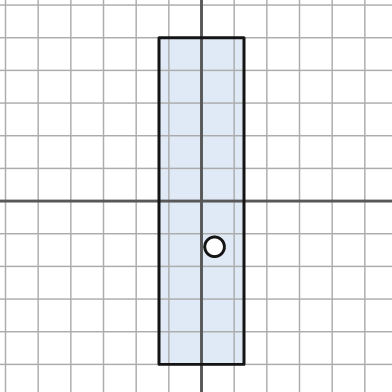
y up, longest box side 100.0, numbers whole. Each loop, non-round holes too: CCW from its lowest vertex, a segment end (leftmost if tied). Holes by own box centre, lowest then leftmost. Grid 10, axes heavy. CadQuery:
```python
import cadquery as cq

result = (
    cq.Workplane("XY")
    .moveTo(-13.0, -50.0)
    .lineTo(13.0, -50.0)
    .lineTo(13.0, 50.0)
    .lineTo(-13.0, 50.0)
    .close()
    .moveTo(4.0, -14.0)
    .circle(3.0)
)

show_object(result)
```